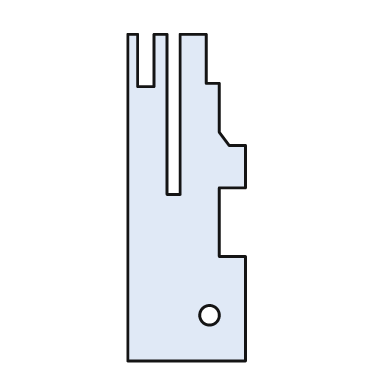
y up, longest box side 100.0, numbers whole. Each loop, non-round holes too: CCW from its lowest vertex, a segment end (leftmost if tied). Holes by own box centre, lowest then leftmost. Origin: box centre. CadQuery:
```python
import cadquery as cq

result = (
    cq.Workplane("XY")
    .moveTo(-18.0, -50.0)
    .lineTo(18.0, -50.0)
    .lineTo(18.0, -18.0)
    .lineTo(10.0, -18.0)
    .lineTo(10.0, 3.0)
    .lineTo(18.0, 3.0)
    .lineTo(18.0, 16.0)
    .lineTo(13.0, 16.0)
    .lineTo(10.0, 20.0)
    .lineTo(10.0, 35.0)
    .lineTo(6.0, 35.0)
    .lineTo(6.0, 50.0)
    .lineTo(-2.0, 50.0)
    .lineTo(-2.0, 1.0)
    .lineTo(-6.0, 1.0)
    .lineTo(-6.0, 50.0)
    .lineTo(-10.0, 50.0)
    .lineTo(-10.0, 34.0)
    .lineTo(-15.0, 34.0)
    .lineTo(-15.0, 50.0)
    .lineTo(-18.0, 50.0)
    .close()
    .moveTo(7.0, -36.0)
    .circle(3.0)
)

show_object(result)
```